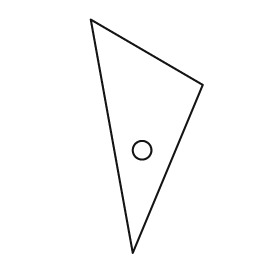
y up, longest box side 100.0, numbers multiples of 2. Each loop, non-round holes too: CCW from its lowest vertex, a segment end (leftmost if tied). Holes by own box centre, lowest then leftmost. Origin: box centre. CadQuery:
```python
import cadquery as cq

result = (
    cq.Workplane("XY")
    .moveTo(-6.0, -50.0)
    .lineTo(24.0, 22.0)
    .lineTo(-24.0, 50.0)
    .close()
    .moveTo(-2.0, -6.0)
    .circle(4.0)
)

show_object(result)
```